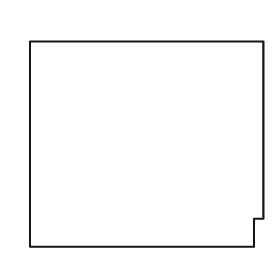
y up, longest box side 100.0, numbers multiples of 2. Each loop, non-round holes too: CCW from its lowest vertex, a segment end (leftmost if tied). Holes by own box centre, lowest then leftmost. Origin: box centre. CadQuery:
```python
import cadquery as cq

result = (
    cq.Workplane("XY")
    .moveTo(-50.0, -44.0)
    .lineTo(46.0, -44.0)
    .lineTo(46.0, -32.0)
    .lineTo(50.0, -32.0)
    .lineTo(50.0, 44.0)
    .lineTo(-50.0, 44.0)
    .close()
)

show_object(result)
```